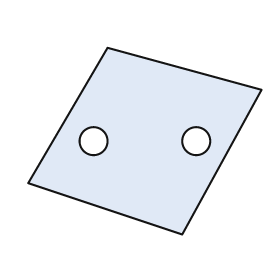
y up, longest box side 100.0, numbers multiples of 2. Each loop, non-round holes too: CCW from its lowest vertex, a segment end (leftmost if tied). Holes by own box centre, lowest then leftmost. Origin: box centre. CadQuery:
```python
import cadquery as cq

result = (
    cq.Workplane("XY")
    .moveTo(16.0, -40.0)
    .lineTo(50.0, 22.0)
    .lineTo(-16.0, 40.0)
    .lineTo(-50.0, -18.0)
    .close()
    .moveTo(-22.0, 0.0)
    .circle(6.0)
    .moveTo(22.0, 0.0)
    .circle(6.0)
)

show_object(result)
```